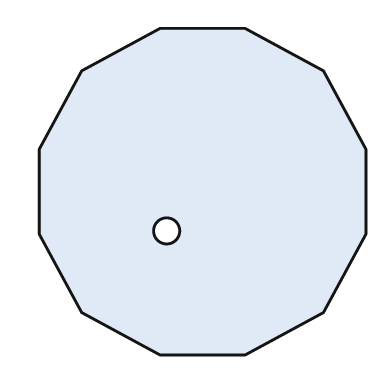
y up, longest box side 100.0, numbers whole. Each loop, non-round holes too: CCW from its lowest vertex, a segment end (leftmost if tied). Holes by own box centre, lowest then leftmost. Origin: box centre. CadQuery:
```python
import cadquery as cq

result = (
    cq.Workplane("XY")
    .moveTo(-13.0, -50.0)
    .lineTo(13.0, -50.0)
    .lineTo(37.0, -37.0)
    .lineTo(50.0, -13.0)
    .lineTo(50.0, 13.0)
    .lineTo(37.0, 37.0)
    .lineTo(13.0, 50.0)
    .lineTo(-13.0, 50.0)
    .lineTo(-37.0, 37.0)
    .lineTo(-50.0, 13.0)
    .lineTo(-50.0, -13.0)
    .lineTo(-37.0, -37.0)
    .close()
    .moveTo(-11.0, -12.0)
    .circle(4.0)
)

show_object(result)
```